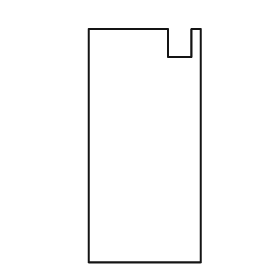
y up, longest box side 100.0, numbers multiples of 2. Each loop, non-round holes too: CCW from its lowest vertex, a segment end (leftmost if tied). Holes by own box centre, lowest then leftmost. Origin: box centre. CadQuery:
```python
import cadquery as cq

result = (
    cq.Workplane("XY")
    .moveTo(-24.0, -50.0)
    .lineTo(24.0, -50.0)
    .lineTo(24.0, 50.0)
    .lineTo(20.0, 50.0)
    .lineTo(20.0, 38.0)
    .lineTo(10.0, 38.0)
    .lineTo(10.0, 50.0)
    .lineTo(-24.0, 50.0)
    .close()
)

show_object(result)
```